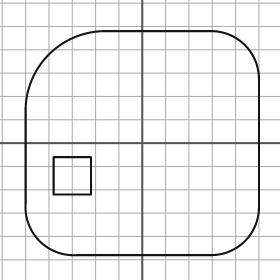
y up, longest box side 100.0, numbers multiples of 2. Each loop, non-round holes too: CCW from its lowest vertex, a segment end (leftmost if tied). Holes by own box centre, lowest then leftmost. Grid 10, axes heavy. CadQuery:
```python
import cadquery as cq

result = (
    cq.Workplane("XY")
    .moveTo(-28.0, -48.0)
    .lineTo(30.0, -48.0)
    .threePointArc((44.0, -42.0), (50.0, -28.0))
    .lineTo(50.0, 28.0)
    .threePointArc((44.0, 42.0), (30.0, 48.0))
    .lineTo(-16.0, 48.0)
    .threePointArc((-40.0, 38.0), (-50.0, 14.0))
    .lineTo(-50.0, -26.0)
    .threePointArc((-44.0, -42.0), (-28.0, -48.0))
    .close()
    .moveTo(-38.0, -22.0)
    .lineTo(-22.0, -22.0)
    .lineTo(-22.0, -6.0)
    .lineTo(-38.0, -6.0)
    .close()
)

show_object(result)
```